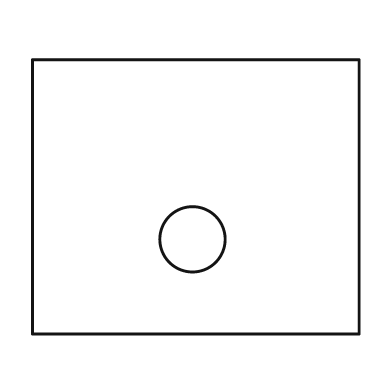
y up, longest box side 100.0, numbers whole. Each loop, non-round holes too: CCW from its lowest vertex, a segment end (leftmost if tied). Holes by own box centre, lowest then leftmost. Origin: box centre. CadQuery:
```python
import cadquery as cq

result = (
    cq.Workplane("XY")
    .moveTo(-50.0, -42.0)
    .lineTo(50.0, -42.0)
    .lineTo(50.0, 42.0)
    .lineTo(-50.0, 42.0)
    .close()
    .moveTo(-1.0, -13.0)
    .circle(10.0)
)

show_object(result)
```